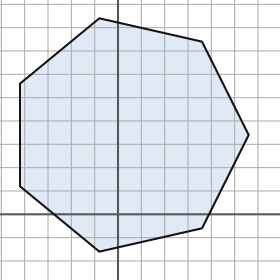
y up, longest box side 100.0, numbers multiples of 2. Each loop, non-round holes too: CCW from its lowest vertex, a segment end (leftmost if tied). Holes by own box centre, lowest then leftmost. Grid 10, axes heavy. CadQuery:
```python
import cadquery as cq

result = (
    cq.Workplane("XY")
    .moveTo(-8.0, -16.0)
    .lineTo(36.0, -6.0)
    .lineTo(56.0, 34.0)
    .lineTo(36.0, 74.0)
    .lineTo(-8.0, 84.0)
    .lineTo(-42.0, 56.0)
    .lineTo(-42.0, 12.0)
    .close()
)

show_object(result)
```